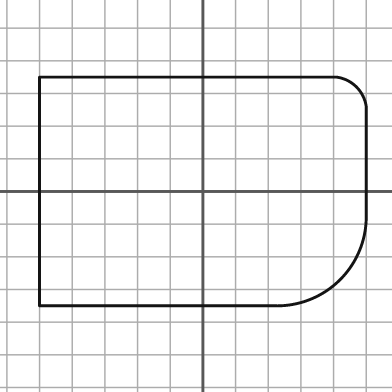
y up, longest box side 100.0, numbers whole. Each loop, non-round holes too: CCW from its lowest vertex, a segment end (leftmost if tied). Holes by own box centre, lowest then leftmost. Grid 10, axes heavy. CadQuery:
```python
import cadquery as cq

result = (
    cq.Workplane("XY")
    .moveTo(-50.0, -35.0)
    .lineTo(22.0, -35.0)
    .threePointArc((42.0, -27.0), (50.0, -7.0))
    .lineTo(50.0, 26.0)
    .threePointArc((47.0, 32.0), (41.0, 35.0))
    .lineTo(-50.0, 35.0)
    .close()
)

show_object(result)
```